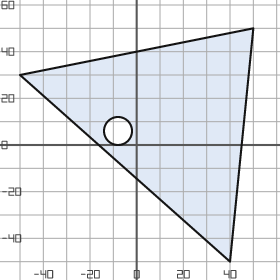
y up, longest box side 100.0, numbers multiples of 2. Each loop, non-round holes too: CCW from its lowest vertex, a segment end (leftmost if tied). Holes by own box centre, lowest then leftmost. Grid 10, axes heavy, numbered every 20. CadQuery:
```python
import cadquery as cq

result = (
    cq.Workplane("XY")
    .moveTo(40.0, -50.0)
    .lineTo(50.0, 50.0)
    .lineTo(-50.0, 30.0)
    .close()
    .moveTo(-8.0, 6.0)
    .circle(6.0)
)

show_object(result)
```